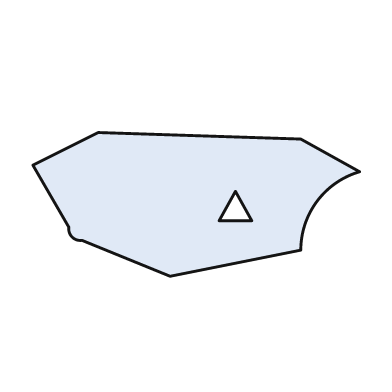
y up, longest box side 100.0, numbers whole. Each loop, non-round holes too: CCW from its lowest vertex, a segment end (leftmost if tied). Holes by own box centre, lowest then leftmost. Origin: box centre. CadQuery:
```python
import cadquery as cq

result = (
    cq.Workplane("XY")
    .moveTo(-8.0, -22.0)
    .lineTo(32.0, -14.0)
    .threePointArc((37.0, 1.0), (50.0, 10.0))
    .lineTo(32.0, 20.0)
    .lineTo(-30.0, 22.0)
    .lineTo(-50.0, 12.0)
    .lineTo(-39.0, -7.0)
    .threePointArc((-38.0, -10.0), (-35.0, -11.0))
    .close()
    .moveTo(7.0, -5.0)
    .lineTo(17.0, -5.0)
    .lineTo(12.0, 4.0)
    .close()
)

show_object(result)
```